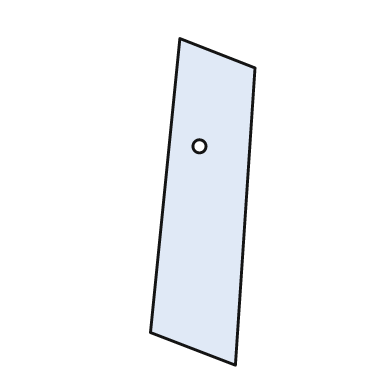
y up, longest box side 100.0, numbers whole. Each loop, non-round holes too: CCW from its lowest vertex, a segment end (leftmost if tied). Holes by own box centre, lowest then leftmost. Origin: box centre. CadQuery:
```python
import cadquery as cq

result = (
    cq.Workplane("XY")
    .moveTo(10.0, -50.0)
    .lineTo(16.0, 41.0)
    .lineTo(-7.0, 50.0)
    .lineTo(-16.0, -40.0)
    .close()
    .moveTo(-1.0, 17.0)
    .circle(2.0)
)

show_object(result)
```